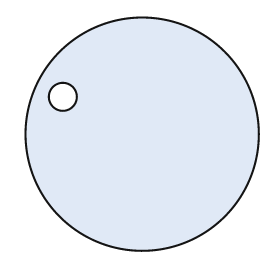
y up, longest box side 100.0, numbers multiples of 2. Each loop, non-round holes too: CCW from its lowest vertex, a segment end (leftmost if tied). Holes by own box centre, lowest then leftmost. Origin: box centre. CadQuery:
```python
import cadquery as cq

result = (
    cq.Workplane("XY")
    .moveTo(0.0, 0.0)
    .circle(50.0)
    .moveTo(-34.0, 16.0)
    .circle(6.0)
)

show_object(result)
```